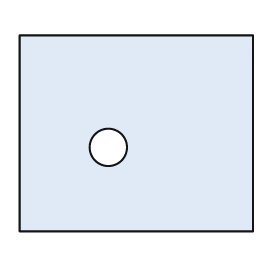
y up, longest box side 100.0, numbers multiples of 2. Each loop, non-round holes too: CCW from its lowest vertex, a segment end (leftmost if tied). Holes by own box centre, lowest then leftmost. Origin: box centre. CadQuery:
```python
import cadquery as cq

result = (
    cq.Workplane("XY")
    .moveTo(-50.0, -42.0)
    .lineTo(50.0, -42.0)
    .lineTo(50.0, 42.0)
    .lineTo(-50.0, 42.0)
    .close()
    .moveTo(-12.0, -6.0)
    .circle(8.0)
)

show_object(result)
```